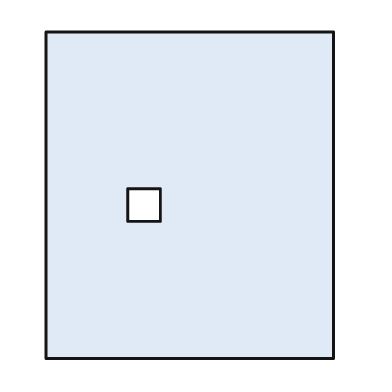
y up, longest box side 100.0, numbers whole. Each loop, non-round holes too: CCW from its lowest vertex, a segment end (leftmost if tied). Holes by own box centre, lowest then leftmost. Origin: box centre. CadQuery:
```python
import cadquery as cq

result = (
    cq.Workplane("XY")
    .moveTo(-44.0, -50.0)
    .lineTo(44.0, -50.0)
    .lineTo(44.0, 50.0)
    .lineTo(-44.0, 50.0)
    .close()
    .moveTo(-19.0, -8.0)
    .lineTo(-9.0, -8.0)
    .lineTo(-9.0, 2.0)
    .lineTo(-19.0, 2.0)
    .close()
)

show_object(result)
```